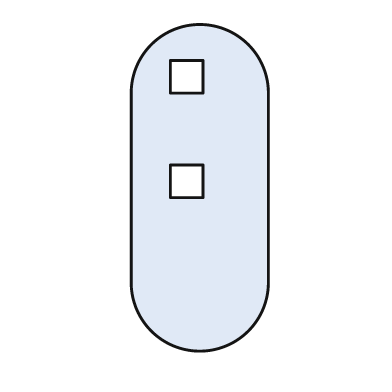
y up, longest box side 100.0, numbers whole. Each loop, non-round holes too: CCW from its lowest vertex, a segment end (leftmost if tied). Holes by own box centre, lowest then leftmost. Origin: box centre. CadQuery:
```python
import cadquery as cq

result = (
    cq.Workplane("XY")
    .moveTo(-21.0, -29.0)
    .threePointArc((0.0, -50.0), (21.0, -29.0))
    .lineTo(21.0, 29.0)
    .threePointArc((0.0, 50.0), (-21.0, 29.0))
    .close()
    .moveTo(-9.0, -3.0)
    .lineTo(1.0, -3.0)
    .lineTo(1.0, 7.0)
    .lineTo(-9.0, 7.0)
    .close()
    .moveTo(-9.0, 29.0)
    .lineTo(1.0, 29.0)
    .lineTo(1.0, 39.0)
    .lineTo(-9.0, 39.0)
    .close()
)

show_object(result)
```